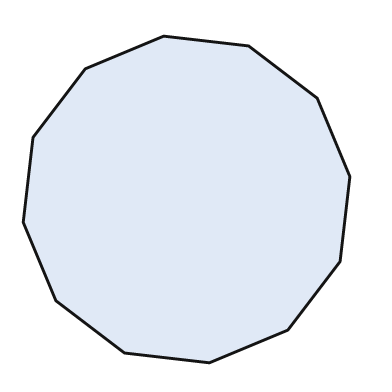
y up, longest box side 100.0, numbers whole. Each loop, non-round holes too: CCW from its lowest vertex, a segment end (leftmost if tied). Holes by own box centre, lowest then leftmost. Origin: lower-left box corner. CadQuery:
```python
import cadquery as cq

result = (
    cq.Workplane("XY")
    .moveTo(57.0, 0.0)
    .lineTo(81.0, 10.0)
    .lineTo(97.0, 31.0)
    .lineTo(100.0, 57.0)
    .lineTo(90.0, 81.0)
    .lineTo(69.0, 97.0)
    .lineTo(43.0, 100.0)
    .lineTo(19.0, 90.0)
    .lineTo(3.0, 69.0)
    .lineTo(0.0, 43.0)
    .lineTo(10.0, 19.0)
    .lineTo(31.0, 3.0)
    .close()
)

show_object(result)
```